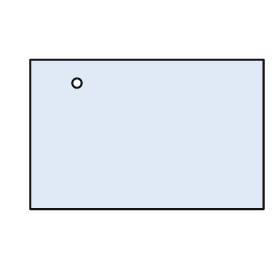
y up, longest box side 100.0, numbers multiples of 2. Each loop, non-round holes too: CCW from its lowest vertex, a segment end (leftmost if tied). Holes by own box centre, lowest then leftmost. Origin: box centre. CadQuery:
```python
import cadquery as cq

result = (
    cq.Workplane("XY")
    .moveTo(-50.0, -32.0)
    .lineTo(50.0, -32.0)
    .lineTo(50.0, 32.0)
    .lineTo(-50.0, 32.0)
    .close()
    .moveTo(-30.0, 22.0)
    .circle(2.0)
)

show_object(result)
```